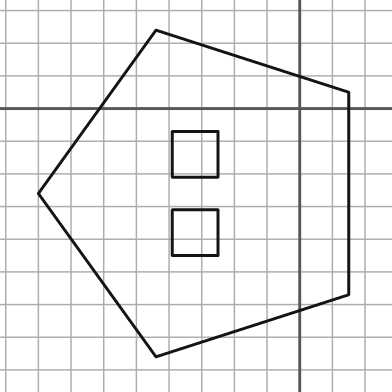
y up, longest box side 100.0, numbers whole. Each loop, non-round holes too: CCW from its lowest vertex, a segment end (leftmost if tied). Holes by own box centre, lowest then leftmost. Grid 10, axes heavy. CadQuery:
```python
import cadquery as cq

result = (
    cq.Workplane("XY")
    .moveTo(-44.0, -76.0)
    .lineTo(15.0, -57.0)
    .lineTo(15.0, 5.0)
    .lineTo(-44.0, 24.0)
    .lineTo(-80.0, -26.0)
    .close()
    .moveTo(-39.0, -45.0)
    .lineTo(-25.0, -45.0)
    .lineTo(-25.0, -31.0)
    .lineTo(-39.0, -31.0)
    .close()
    .moveTo(-39.0, -21.0)
    .lineTo(-25.0, -21.0)
    .lineTo(-25.0, -7.0)
    .lineTo(-39.0, -7.0)
    .close()
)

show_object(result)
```